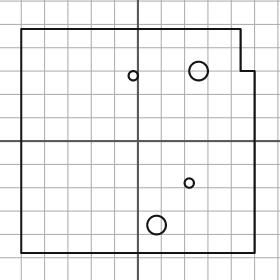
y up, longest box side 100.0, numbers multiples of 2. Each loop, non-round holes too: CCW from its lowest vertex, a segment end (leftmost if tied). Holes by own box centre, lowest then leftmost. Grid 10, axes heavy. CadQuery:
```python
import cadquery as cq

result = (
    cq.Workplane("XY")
    .moveTo(-50.0, -48.0)
    .lineTo(50.0, -48.0)
    .lineTo(50.0, 30.0)
    .lineTo(44.0, 30.0)
    .lineTo(44.0, 48.0)
    .lineTo(-50.0, 48.0)
    .close()
    .moveTo(8.0, -36.0)
    .circle(4.0)
    .moveTo(22.0, -18.0)
    .circle(2.0)
    .moveTo(-2.0, 28.0)
    .circle(2.0)
    .moveTo(26.0, 30.0)
    .circle(4.0)
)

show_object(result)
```